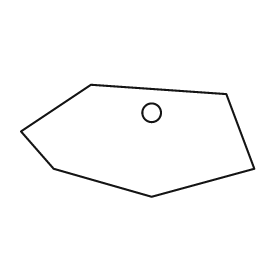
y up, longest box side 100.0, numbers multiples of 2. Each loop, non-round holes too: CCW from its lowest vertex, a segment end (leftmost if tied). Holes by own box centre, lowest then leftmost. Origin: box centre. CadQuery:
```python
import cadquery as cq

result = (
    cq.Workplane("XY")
    .moveTo(6.0, -24.0)
    .lineTo(50.0, -12.0)
    .lineTo(38.0, 20.0)
    .lineTo(-20.0, 24.0)
    .lineTo(-50.0, 4.0)
    .lineTo(-36.0, -12.0)
    .close()
    .moveTo(6.0, 12.0)
    .circle(4.0)
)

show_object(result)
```